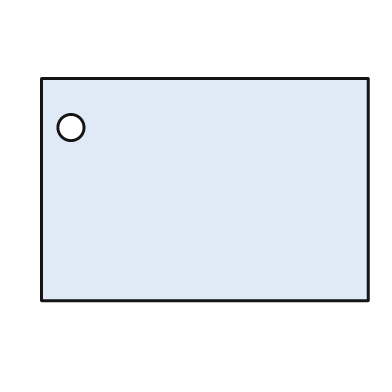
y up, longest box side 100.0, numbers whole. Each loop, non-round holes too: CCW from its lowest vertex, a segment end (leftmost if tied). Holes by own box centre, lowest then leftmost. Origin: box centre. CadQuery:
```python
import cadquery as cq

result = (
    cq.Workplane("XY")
    .moveTo(-50.0, -34.0)
    .lineTo(50.0, -34.0)
    .lineTo(50.0, 34.0)
    .lineTo(-50.0, 34.0)
    .close()
    .moveTo(-41.0, 19.0)
    .circle(4.0)
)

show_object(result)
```